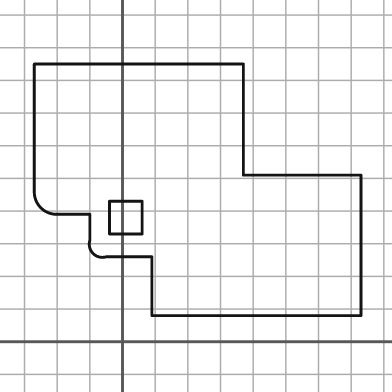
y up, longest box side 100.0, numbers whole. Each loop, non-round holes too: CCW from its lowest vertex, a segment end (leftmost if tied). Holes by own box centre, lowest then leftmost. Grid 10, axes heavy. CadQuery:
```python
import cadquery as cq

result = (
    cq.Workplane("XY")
    .moveTo(9.0, 8.0)
    .lineTo(73.0, 8.0)
    .lineTo(73.0, 51.0)
    .lineTo(37.0, 51.0)
    .lineTo(37.0, 85.0)
    .lineTo(-27.0, 85.0)
    .lineTo(-27.0, 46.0)
    .threePointArc((-25.0, 41.0), (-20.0, 39.0))
    .lineTo(-10.0, 39.0)
    .lineTo(-10.0, 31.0)
    .threePointArc((-9.0, 27.0), (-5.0, 26.0))
    .lineTo(9.0, 26.0)
    .close()
    .moveTo(-4.0, 33.0)
    .lineTo(6.0, 33.0)
    .lineTo(6.0, 43.0)
    .lineTo(-4.0, 43.0)
    .close()
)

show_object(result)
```